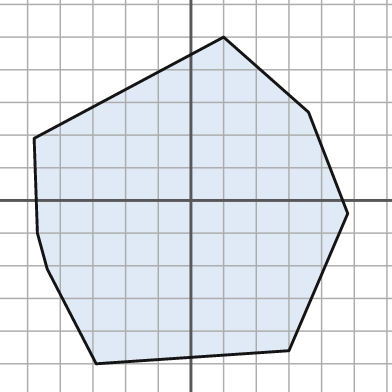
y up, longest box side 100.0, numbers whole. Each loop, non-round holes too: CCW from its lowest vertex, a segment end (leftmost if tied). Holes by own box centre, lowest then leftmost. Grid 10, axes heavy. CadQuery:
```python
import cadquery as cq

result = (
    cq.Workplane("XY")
    .moveTo(-29.0, -50.0)
    .lineTo(30.0, -46.0)
    .lineTo(48.0, -4.0)
    .lineTo(36.0, 27.0)
    .lineTo(10.0, 50.0)
    .lineTo(-48.0, 19.0)
    .lineTo(-47.0, -10.0)
    .lineTo(-44.0, -21.0)
    .close()
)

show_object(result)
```